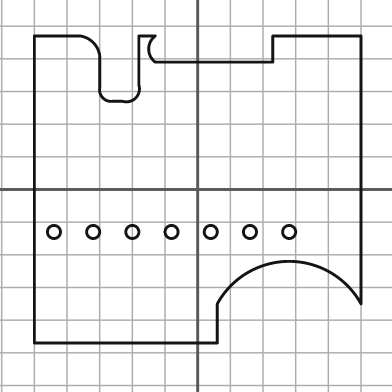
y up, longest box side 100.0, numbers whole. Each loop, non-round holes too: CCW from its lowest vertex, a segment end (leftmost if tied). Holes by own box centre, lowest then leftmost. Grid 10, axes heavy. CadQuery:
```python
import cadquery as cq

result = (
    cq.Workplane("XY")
    .moveTo(-50.0, -47.0)
    .lineTo(6.0, -47.0)
    .lineTo(6.0, -35.0)
    .threePointArc((28.0, -22.0), (50.0, -35.0))
    .lineTo(50.0, 47.0)
    .lineTo(23.0, 47.0)
    .lineTo(23.0, 39.0)
    .lineTo(-13.0, 39.0)
    .threePointArc((-15.0, 43.0), (-13.0, 47.0))
    .lineTo(-18.0, 47.0)
    .lineTo(-18.0, 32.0)
    .threePointArc((-19.0, 28.0), (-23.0, 27.0))
    .lineTo(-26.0, 27.0)
    .threePointArc((-29.0, 28.0), (-30.0, 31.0))
    .lineTo(-30.0, 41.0)
    .threePointArc((-32.0, 45.0), (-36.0, 47.0))
    .lineTo(-50.0, 47.0)
    .close()
    .moveTo(-44.0, -13.0)
    .circle(2.0)
    .moveTo(-32.0, -13.0)
    .circle(2.0)
    .moveTo(-20.0, -13.0)
    .circle(2.0)
    .moveTo(-8.0, -13.0)
    .circle(2.0)
    .moveTo(4.0, -13.0)
    .circle(2.0)
    .moveTo(16.0, -13.0)
    .circle(2.0)
    .moveTo(28.0, -13.0)
    .circle(2.0)
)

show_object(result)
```